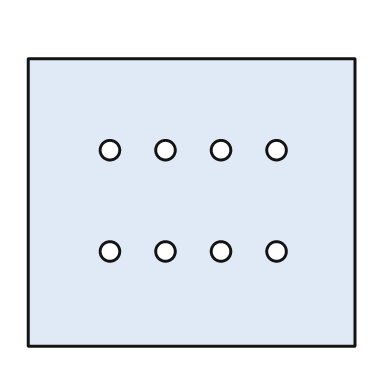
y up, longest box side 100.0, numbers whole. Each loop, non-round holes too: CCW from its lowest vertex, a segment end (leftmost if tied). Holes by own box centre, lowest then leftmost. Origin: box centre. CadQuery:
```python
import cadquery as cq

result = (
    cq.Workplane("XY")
    .moveTo(-50.0, -44.0)
    .lineTo(50.0, -44.0)
    .lineTo(50.0, 44.0)
    .lineTo(-50.0, 44.0)
    .close()
    .moveTo(-25.0, -15.0)
    .circle(3.0)
    .moveTo(-8.0, -15.0)
    .circle(3.0)
    .moveTo(9.0, -15.0)
    .circle(3.0)
    .moveTo(26.0, -15.0)
    .circle(3.0)
    .moveTo(-25.0, 16.0)
    .circle(3.0)
    .moveTo(-8.0, 16.0)
    .circle(3.0)
    .moveTo(9.0, 16.0)
    .circle(3.0)
    .moveTo(26.0, 16.0)
    .circle(3.0)
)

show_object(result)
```